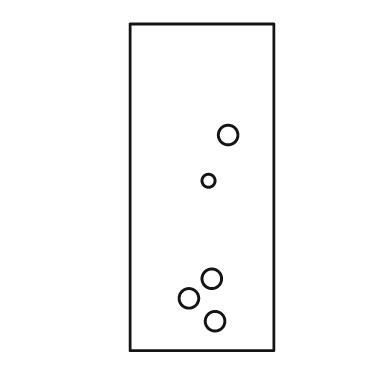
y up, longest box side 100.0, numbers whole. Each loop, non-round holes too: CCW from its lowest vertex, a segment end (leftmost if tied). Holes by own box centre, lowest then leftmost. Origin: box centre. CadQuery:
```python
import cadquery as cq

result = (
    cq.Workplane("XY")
    .moveTo(-22.0, -50.0)
    .lineTo(22.0, -50.0)
    .lineTo(22.0, 50.0)
    .lineTo(-22.0, 50.0)
    .close()
    .moveTo(4.0, -41.0)
    .circle(3.0)
    .moveTo(-4.0, -34.0)
    .circle(3.0)
    .moveTo(3.0, -28.0)
    .circle(3.0)
    .moveTo(2.0, 2.0)
    .circle(2.0)
    .moveTo(8.0, 16.0)
    .circle(3.0)
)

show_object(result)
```